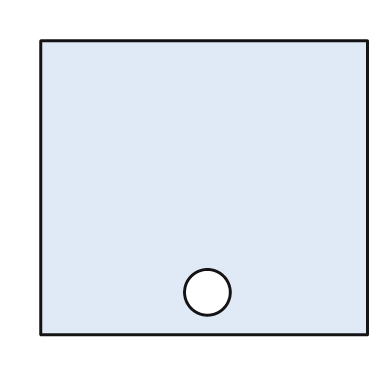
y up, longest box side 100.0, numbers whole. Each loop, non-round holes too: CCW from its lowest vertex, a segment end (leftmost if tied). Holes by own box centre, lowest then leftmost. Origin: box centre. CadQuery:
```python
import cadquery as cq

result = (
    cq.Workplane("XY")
    .moveTo(-50.0, -45.0)
    .lineTo(50.0, -45.0)
    .lineTo(50.0, 45.0)
    .lineTo(-50.0, 45.0)
    .close()
    .moveTo(1.0, -32.0)
    .circle(7.0)
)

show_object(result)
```